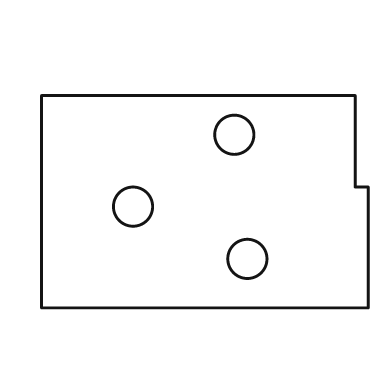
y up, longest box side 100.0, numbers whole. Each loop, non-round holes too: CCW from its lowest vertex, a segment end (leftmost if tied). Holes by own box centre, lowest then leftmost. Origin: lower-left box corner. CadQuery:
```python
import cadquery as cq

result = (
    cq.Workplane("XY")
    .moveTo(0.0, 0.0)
    .lineTo(100.0, 0.0)
    .lineTo(100.0, 37.0)
    .lineTo(96.0, 37.0)
    .lineTo(96.0, 65.0)
    .lineTo(0.0, 65.0)
    .close()
    .moveTo(63.0, 15.0)
    .circle(6.0)
    .moveTo(28.0, 31.0)
    .circle(6.0)
    .moveTo(59.0, 53.0)
    .circle(6.0)
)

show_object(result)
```